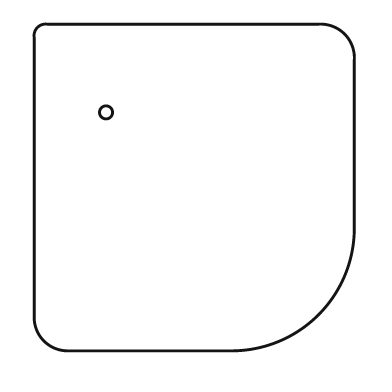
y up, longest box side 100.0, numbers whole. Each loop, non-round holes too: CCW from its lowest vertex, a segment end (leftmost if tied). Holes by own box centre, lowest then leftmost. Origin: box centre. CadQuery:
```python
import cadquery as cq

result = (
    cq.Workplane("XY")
    .moveTo(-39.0, -50.0)
    .lineTo(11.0, -50.0)
    .threePointArc((38.0, -39.0), (49.0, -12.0))
    .lineTo(49.0, 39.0)
    .threePointArc((46.0, 47.0), (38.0, 50.0))
    .lineTo(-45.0, 50.0)
    .threePointArc((-48.0, 49.0), (-49.0, 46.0))
    .lineTo(-49.0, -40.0)
    .threePointArc((-46.0, -47.0), (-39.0, -50.0))
    .close()
    .moveTo(-27.0, 23.0)
    .circle(2.0)
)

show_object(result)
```